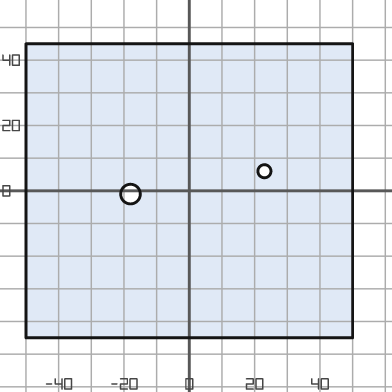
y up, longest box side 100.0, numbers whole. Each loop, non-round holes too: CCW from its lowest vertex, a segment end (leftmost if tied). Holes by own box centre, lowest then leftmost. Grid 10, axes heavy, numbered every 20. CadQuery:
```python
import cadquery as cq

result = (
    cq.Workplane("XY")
    .moveTo(-50.0, -45.0)
    .lineTo(50.0, -45.0)
    .lineTo(50.0, 45.0)
    .lineTo(-50.0, 45.0)
    .close()
    .moveTo(-18.0, -1.0)
    .circle(3.0)
    .moveTo(23.0, 6.0)
    .circle(2.0)
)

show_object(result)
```